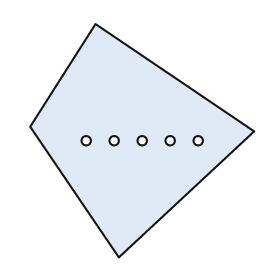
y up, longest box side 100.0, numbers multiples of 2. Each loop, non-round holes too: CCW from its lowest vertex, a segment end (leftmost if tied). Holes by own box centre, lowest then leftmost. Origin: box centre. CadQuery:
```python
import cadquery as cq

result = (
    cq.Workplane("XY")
    .moveTo(-10.0, -50.0)
    .lineTo(48.0, 4.0)
    .lineTo(-20.0, 50.0)
    .lineTo(-48.0, 6.0)
    .close()
    .moveTo(-24.0, 0.0)
    .circle(2.0)
    .moveTo(-12.0, 0.0)
    .circle(2.0)
    .moveTo(0.0, 0.0)
    .circle(2.0)
    .moveTo(12.0, 0.0)
    .circle(2.0)
    .moveTo(24.0, 0.0)
    .circle(2.0)
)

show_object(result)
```